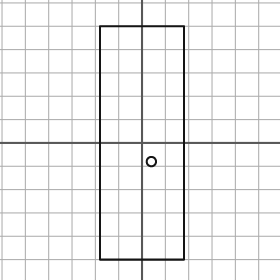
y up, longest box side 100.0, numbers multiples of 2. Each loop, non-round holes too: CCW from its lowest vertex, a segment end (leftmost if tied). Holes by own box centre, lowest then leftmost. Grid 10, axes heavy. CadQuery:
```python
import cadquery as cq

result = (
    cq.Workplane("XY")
    .moveTo(-18.0, -50.0)
    .lineTo(18.0, -50.0)
    .lineTo(18.0, 50.0)
    .lineTo(-18.0, 50.0)
    .close()
    .moveTo(4.0, -8.0)
    .circle(2.0)
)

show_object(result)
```